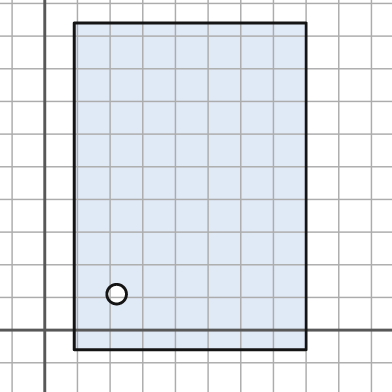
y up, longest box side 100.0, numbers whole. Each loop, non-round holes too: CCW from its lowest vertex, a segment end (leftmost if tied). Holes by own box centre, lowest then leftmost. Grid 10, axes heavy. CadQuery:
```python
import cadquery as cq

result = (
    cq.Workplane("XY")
    .moveTo(9.0, -6.0)
    .lineTo(80.0, -6.0)
    .lineTo(80.0, 94.0)
    .lineTo(9.0, 94.0)
    .close()
    .moveTo(22.0, 11.0)
    .circle(3.0)
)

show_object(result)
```